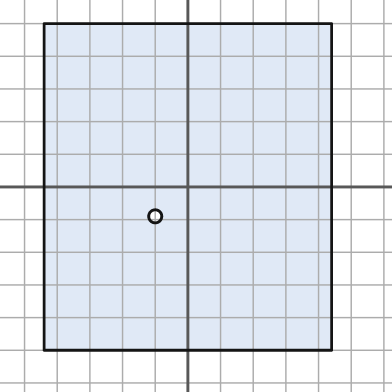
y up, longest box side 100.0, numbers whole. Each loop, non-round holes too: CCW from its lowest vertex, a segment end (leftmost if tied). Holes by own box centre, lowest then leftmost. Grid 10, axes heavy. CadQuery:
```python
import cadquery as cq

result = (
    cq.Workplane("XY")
    .moveTo(-44.0, -50.0)
    .lineTo(44.0, -50.0)
    .lineTo(44.0, 50.0)
    .lineTo(-44.0, 50.0)
    .close()
    .moveTo(-10.0, -9.0)
    .circle(2.0)
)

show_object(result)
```